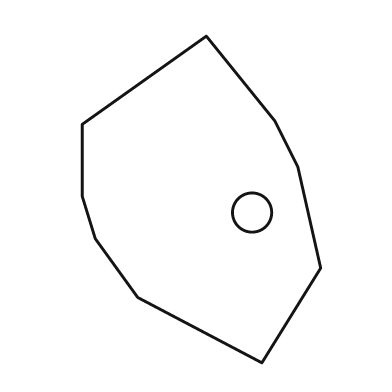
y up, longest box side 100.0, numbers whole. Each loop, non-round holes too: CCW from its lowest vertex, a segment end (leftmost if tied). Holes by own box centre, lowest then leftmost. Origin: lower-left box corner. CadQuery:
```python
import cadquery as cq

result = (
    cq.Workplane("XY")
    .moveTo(55.0, 0.0)
    .lineTo(73.0, 29.0)
    .lineTo(66.0, 60.0)
    .lineTo(59.0, 74.0)
    .lineTo(38.0, 100.0)
    .lineTo(0.0, 73.0)
    .lineTo(0.0, 51.0)
    .lineTo(4.0, 38.0)
    .lineTo(17.0, 20.0)
    .close()
    .moveTo(52.0, 46.0)
    .circle(6.0)
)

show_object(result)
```